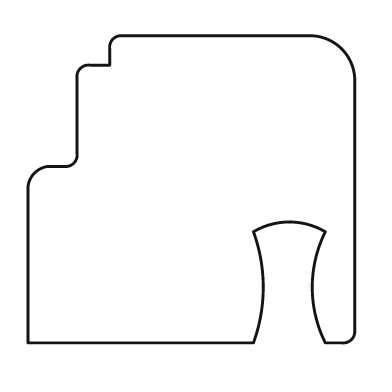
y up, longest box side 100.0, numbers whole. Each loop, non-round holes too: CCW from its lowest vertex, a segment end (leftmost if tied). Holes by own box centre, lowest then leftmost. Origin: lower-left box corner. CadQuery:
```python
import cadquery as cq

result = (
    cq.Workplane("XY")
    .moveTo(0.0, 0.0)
    .lineTo(69.0, 0.0)
    .threePointArc((72.0, 17.0), (69.0, 34.0))
    .threePointArc((80.0, 37.0), (91.0, 34.0))
    .threePointArc((87.0, 17.0), (91.0, 0.0))
    .lineTo(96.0, 0.0)
    .threePointArc((99.0, 1.0), (100.0, 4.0))
    .lineTo(100.0, 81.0)
    .threePointArc((96.0, 90.0), (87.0, 94.0))
    .lineTo(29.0, 94.0)
    .threePointArc((26.0, 93.0), (25.0, 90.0))
    .lineTo(25.0, 85.0)
    .lineTo(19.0, 85.0)
    .threePointArc((16.0, 84.0), (15.0, 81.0))
    .lineTo(15.0, 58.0)
    .threePointArc((14.0, 55.0), (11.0, 54.0))
    .lineTo(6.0, 54.0)
    .threePointArc((2.0, 52.0), (0.0, 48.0))
    .close()
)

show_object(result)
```